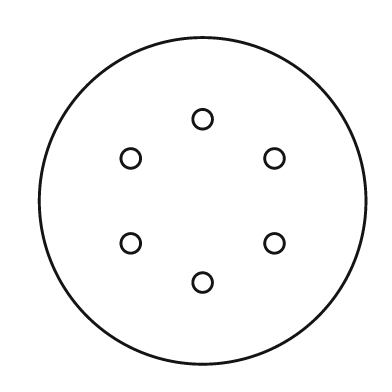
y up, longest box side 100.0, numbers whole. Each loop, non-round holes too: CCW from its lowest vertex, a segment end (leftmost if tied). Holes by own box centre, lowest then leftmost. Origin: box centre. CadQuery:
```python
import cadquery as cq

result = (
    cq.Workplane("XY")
    .moveTo(0.0, 0.0)
    .circle(50.0)
    .moveTo(0.0, -25.0)
    .circle(3.0)
    .moveTo(-22.0, -13.0)
    .circle(3.0)
    .moveTo(22.0, -13.0)
    .circle(3.0)
    .moveTo(-22.0, 13.0)
    .circle(3.0)
    .moveTo(22.0, 13.0)
    .circle(3.0)
    .moveTo(0.0, 25.0)
    .circle(3.0)
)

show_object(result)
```